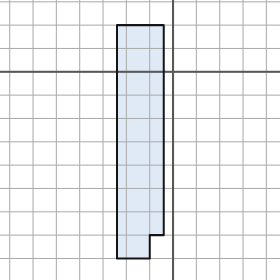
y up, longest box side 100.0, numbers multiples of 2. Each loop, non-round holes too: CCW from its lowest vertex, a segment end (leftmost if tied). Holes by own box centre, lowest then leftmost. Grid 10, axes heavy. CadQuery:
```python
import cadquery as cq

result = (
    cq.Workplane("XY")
    .moveTo(-24.0, -80.0)
    .lineTo(-10.0, -80.0)
    .lineTo(-10.0, -70.0)
    .lineTo(-4.0, -70.0)
    .lineTo(-4.0, 20.0)
    .lineTo(-24.0, 20.0)
    .close()
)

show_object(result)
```